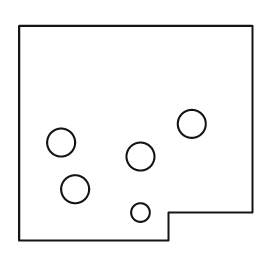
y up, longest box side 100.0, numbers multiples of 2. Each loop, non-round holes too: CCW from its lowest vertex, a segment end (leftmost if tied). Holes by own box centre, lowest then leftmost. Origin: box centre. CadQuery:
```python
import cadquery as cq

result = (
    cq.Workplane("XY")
    .moveTo(-50.0, -46.0)
    .lineTo(14.0, -46.0)
    .lineTo(14.0, -34.0)
    .lineTo(50.0, -34.0)
    .lineTo(50.0, 46.0)
    .lineTo(-50.0, 46.0)
    .close()
    .moveTo(2.0, -34.0)
    .circle(4.0)
    .moveTo(-26.0, -24.0)
    .circle(6.0)
    .moveTo(2.0, -10.0)
    .circle(6.0)
    .moveTo(-32.0, -4.0)
    .circle(6.0)
    .moveTo(24.0, 4.0)
    .circle(6.0)
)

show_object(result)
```